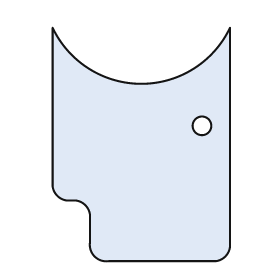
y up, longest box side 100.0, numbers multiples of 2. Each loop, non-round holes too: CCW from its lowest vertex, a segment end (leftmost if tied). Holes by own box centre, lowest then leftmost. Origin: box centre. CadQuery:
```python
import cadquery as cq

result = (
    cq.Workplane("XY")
    .moveTo(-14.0, -50.0)
    .lineTo(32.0, -50.0)
    .threePointArc((36.0, -48.0), (38.0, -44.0))
    .lineTo(38.0, 50.0)
    .threePointArc((0.0, 26.0), (-38.0, 50.0))
    .lineTo(-38.0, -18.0)
    .threePointArc((-36.0, -22.0), (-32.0, -24.0))
    .lineTo(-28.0, -24.0)
    .threePointArc((-24.0, -26.0), (-22.0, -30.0))
    .lineTo(-22.0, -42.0)
    .threePointArc((-20.0, -48.0), (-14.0, -50.0))
    .close()
    .moveTo(26.0, 8.0)
    .circle(4.0)
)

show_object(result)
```